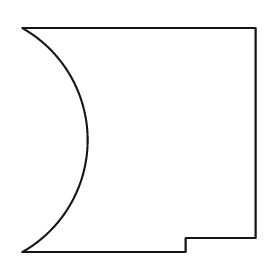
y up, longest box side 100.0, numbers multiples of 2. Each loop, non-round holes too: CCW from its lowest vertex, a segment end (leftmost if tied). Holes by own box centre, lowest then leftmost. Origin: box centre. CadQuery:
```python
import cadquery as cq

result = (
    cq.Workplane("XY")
    .moveTo(-50.0, -48.0)
    .lineTo(20.0, -48.0)
    .lineTo(20.0, -42.0)
    .lineTo(50.0, -42.0)
    .lineTo(50.0, 48.0)
    .lineTo(-50.0, 48.0)
    .threePointArc((-22.0, 0.0), (-50.0, -48.0))
    .close()
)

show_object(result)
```